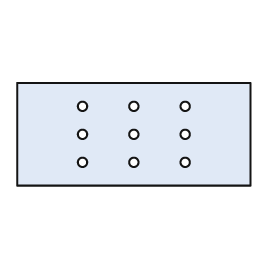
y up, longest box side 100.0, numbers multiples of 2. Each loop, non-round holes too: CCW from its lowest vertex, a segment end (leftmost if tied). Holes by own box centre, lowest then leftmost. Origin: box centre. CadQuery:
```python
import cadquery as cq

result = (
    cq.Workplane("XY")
    .moveTo(-50.0, -22.0)
    .lineTo(50.0, -22.0)
    .lineTo(50.0, 22.0)
    .lineTo(-50.0, 22.0)
    .close()
    .moveTo(-22.0, -12.0)
    .circle(2.0)
    .moveTo(0.0, -12.0)
    .circle(2.0)
    .moveTo(22.0, -12.0)
    .circle(2.0)
    .moveTo(-22.0, 0.0)
    .circle(2.0)
    .moveTo(0.0, 0.0)
    .circle(2.0)
    .moveTo(22.0, 0.0)
    .circle(2.0)
    .moveTo(-22.0, 12.0)
    .circle(2.0)
    .moveTo(0.0, 12.0)
    .circle(2.0)
    .moveTo(22.0, 12.0)
    .circle(2.0)
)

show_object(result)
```